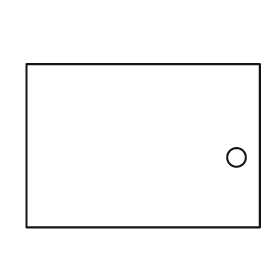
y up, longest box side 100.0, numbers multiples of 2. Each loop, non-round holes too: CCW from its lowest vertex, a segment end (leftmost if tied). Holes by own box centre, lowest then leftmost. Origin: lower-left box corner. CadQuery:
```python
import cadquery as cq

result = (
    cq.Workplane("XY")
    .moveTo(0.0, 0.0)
    .lineTo(100.0, 0.0)
    .lineTo(100.0, 70.0)
    .lineTo(0.0, 70.0)
    .close()
    .moveTo(90.0, 30.0)
    .circle(4.0)
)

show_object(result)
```